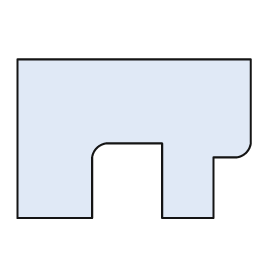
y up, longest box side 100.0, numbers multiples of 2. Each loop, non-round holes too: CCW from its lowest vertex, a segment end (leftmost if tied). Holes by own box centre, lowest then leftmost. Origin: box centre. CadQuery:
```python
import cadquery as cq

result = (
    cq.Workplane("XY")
    .moveTo(-50.0, -34.0)
    .lineTo(-18.0, -34.0)
    .lineTo(-18.0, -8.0)
    .threePointArc((-16.0, -4.0), (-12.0, -2.0))
    .lineTo(12.0, -2.0)
    .lineTo(12.0, -34.0)
    .lineTo(34.0, -34.0)
    .lineTo(34.0, -8.0)
    .lineTo(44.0, -8.0)
    .threePointArc((48.0, -6.0), (50.0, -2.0))
    .lineTo(50.0, 34.0)
    .lineTo(-50.0, 34.0)
    .close()
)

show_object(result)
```